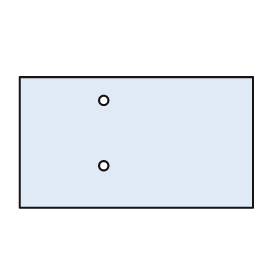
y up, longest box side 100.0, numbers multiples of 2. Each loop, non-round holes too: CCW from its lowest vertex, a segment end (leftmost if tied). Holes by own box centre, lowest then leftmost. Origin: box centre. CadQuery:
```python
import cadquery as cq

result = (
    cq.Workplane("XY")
    .moveTo(-50.0, -28.0)
    .lineTo(50.0, -28.0)
    .lineTo(50.0, 28.0)
    .lineTo(-50.0, 28.0)
    .close()
    .moveTo(-14.0, -10.0)
    .circle(2.0)
    .moveTo(-14.0, 18.0)
    .circle(2.0)
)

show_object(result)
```